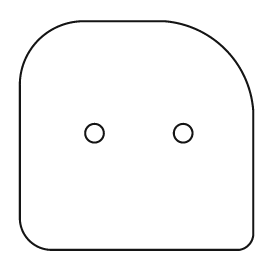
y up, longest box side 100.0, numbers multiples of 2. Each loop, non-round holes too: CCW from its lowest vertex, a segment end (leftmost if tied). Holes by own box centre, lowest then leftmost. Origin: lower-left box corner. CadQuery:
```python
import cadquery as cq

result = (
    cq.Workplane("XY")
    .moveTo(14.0, 0.0)
    .lineTo(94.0, 0.0)
    .threePointArc((98.0, 2.0), (100.0, 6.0))
    .lineTo(100.0, 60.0)
    .threePointArc((88.0, 86.0), (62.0, 98.0))
    .lineTo(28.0, 98.0)
    .threePointArc((8.0, 90.0), (0.0, 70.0))
    .lineTo(0.0, 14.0)
    .threePointArc((4.0, 4.0), (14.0, 0.0))
    .close()
    .moveTo(32.0, 50.0)
    .circle(4.0)
    .moveTo(70.0, 50.0)
    .circle(4.0)
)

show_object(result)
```